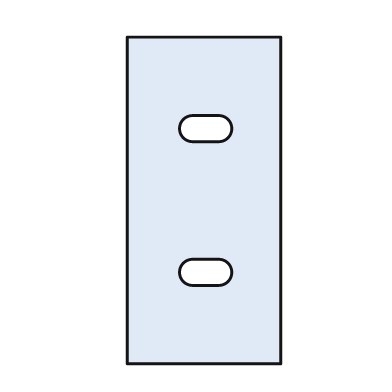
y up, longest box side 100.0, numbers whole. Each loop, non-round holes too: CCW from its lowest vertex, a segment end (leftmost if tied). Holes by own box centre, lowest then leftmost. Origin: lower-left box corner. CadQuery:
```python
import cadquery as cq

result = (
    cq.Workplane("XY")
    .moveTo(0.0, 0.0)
    .lineTo(47.0, 0.0)
    .lineTo(47.0, 100.0)
    .lineTo(0.0, 100.0)
    .close()
    .moveTo(20.0, 24.0)
    .lineTo(28.0, 24.0)
    .threePointArc((32.0, 28.0), (28.0, 32.0))
    .lineTo(20.0, 32.0)
    .threePointArc((16.0, 28.0), (20.0, 24.0))
    .close()
    .moveTo(20.0, 68.0)
    .lineTo(28.0, 68.0)
    .threePointArc((32.0, 72.0), (28.0, 76.0))
    .lineTo(20.0, 76.0)
    .threePointArc((16.0, 72.0), (20.0, 68.0))
    .close()
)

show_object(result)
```